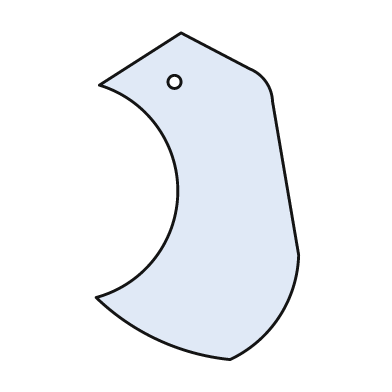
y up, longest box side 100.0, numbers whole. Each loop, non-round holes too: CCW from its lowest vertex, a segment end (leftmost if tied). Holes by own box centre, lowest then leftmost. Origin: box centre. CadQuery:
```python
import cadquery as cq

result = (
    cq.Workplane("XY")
    .moveTo(10.0, -50.0)
    .threePointArc((25.0, -37.0), (31.0, -18.0))
    .lineTo(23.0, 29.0)
    .threePointArc((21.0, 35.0), (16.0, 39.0))
    .lineTo(-5.0, 50.0)
    .lineTo(-30.0, 34.0)
    .threePointArc((-6.0, 1.0), (-31.0, -31.0))
    .threePointArc((-12.0, -44.0), (10.0, -50.0))
    .close()
    .moveTo(-7.0, 35.0)
    .circle(2.0)
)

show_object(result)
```